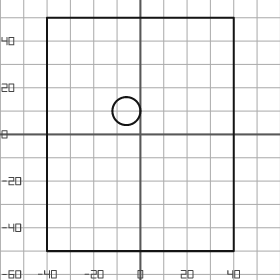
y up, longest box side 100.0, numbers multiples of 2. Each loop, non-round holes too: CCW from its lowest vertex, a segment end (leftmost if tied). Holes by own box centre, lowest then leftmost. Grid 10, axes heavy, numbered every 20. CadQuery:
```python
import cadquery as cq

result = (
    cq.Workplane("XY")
    .moveTo(-40.0, -50.0)
    .lineTo(40.0, -50.0)
    .lineTo(40.0, 50.0)
    .lineTo(-40.0, 50.0)
    .close()
    .moveTo(-6.0, 10.0)
    .circle(6.0)
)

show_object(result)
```